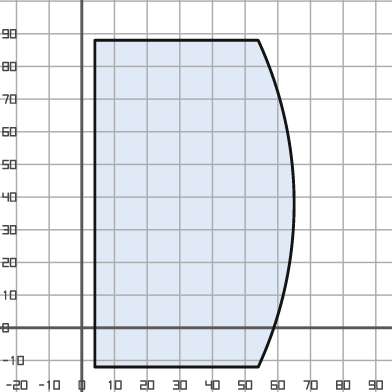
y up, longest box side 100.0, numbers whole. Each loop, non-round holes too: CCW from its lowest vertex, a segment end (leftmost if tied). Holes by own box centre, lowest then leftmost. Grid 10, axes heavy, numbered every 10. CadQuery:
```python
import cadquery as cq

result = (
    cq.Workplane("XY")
    .moveTo(4.0, -12.0)
    .lineTo(54.0, -12.0)
    .threePointArc((65.0, 38.0), (54.0, 88.0))
    .lineTo(4.0, 88.0)
    .close()
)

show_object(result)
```